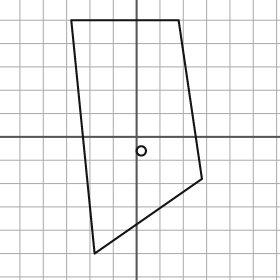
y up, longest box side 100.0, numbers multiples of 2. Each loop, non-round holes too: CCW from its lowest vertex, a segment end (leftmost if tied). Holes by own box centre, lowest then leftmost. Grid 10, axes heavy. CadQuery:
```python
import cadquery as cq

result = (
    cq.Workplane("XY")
    .moveTo(-18.0, -50.0)
    .lineTo(28.0, -18.0)
    .lineTo(18.0, 50.0)
    .lineTo(-28.0, 50.0)
    .close()
    .moveTo(2.0, -6.0)
    .circle(2.0)
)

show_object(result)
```